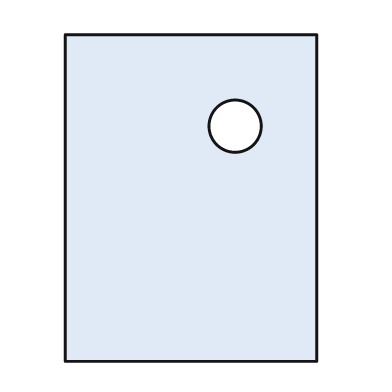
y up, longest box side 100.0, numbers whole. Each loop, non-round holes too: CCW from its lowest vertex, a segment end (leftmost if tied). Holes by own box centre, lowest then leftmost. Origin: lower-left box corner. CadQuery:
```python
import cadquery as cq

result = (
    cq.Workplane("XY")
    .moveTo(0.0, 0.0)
    .lineTo(77.0, 0.0)
    .lineTo(77.0, 100.0)
    .lineTo(0.0, 100.0)
    .close()
    .moveTo(52.0, 72.0)
    .circle(8.0)
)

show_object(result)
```